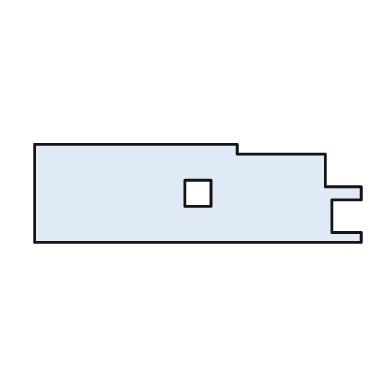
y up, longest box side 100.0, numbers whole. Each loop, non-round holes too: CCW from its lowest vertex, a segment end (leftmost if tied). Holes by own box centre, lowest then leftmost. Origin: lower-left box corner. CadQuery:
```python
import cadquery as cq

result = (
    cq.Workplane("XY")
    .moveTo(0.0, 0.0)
    .lineTo(100.0, 0.0)
    .lineTo(100.0, 3.0)
    .lineTo(91.0, 3.0)
    .lineTo(91.0, 13.0)
    .lineTo(100.0, 13.0)
    .lineTo(100.0, 17.0)
    .lineTo(89.0, 17.0)
    .lineTo(89.0, 27.0)
    .lineTo(62.0, 27.0)
    .lineTo(62.0, 30.0)
    .lineTo(0.0, 30.0)
    .close()
    .moveTo(46.0, 11.0)
    .lineTo(54.0, 11.0)
    .lineTo(54.0, 19.0)
    .lineTo(46.0, 19.0)
    .close()
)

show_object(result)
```